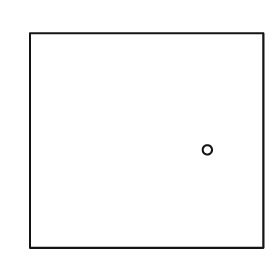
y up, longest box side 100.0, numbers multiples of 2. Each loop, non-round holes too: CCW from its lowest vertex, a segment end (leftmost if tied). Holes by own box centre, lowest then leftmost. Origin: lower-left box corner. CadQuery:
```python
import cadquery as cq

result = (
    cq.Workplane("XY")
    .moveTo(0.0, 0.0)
    .lineTo(100.0, 0.0)
    .lineTo(100.0, 92.0)
    .lineTo(0.0, 92.0)
    .close()
    .moveTo(76.0, 42.0)
    .circle(2.0)
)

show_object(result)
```